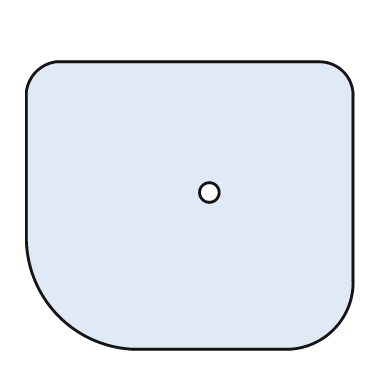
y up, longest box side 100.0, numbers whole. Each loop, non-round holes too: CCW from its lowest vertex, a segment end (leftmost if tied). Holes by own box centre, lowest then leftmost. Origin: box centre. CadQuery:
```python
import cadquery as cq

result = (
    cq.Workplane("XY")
    .moveTo(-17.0, -44.0)
    .lineTo(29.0, -44.0)
    .threePointArc((44.0, -38.0), (50.0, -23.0))
    .lineTo(50.0, 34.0)
    .threePointArc((47.0, 41.0), (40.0, 44.0))
    .lineTo(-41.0, 44.0)
    .threePointArc((-47.0, 41.0), (-50.0, 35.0))
    .lineTo(-50.0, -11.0)
    .threePointArc((-40.0, -34.0), (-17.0, -44.0))
    .close()
    .moveTo(6.0, 4.0)
    .circle(3.0)
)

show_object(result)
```